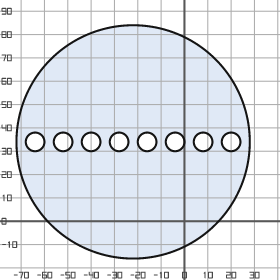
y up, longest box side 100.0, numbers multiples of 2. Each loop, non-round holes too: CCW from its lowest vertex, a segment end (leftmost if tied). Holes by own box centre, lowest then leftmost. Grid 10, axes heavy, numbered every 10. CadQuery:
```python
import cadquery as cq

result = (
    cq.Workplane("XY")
    .moveTo(-22.0, 34.0)
    .circle(50.0)
    .moveTo(-64.0, 34.0)
    .circle(4.0)
    .moveTo(-52.0, 34.0)
    .circle(4.0)
    .moveTo(-40.0, 34.0)
    .circle(4.0)
    .moveTo(-28.0, 34.0)
    .circle(4.0)
    .moveTo(-16.0, 34.0)
    .circle(4.0)
    .moveTo(-4.0, 34.0)
    .circle(4.0)
    .moveTo(8.0, 34.0)
    .circle(4.0)
    .moveTo(20.0, 34.0)
    .circle(4.0)
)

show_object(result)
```